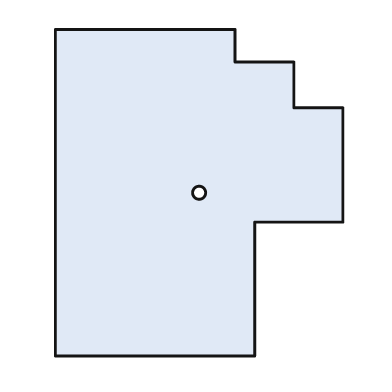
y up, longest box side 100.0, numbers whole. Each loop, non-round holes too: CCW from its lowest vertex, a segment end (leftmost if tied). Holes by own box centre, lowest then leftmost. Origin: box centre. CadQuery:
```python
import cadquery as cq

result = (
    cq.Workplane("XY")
    .moveTo(-44.0, -50.0)
    .lineTo(17.0, -50.0)
    .lineTo(17.0, -9.0)
    .lineTo(44.0, -9.0)
    .lineTo(44.0, 26.0)
    .lineTo(29.0, 26.0)
    .lineTo(29.0, 40.0)
    .lineTo(11.0, 40.0)
    .lineTo(11.0, 50.0)
    .lineTo(-44.0, 50.0)
    .close()
    .moveTo(0.0, 0.0)
    .circle(2.0)
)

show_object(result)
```